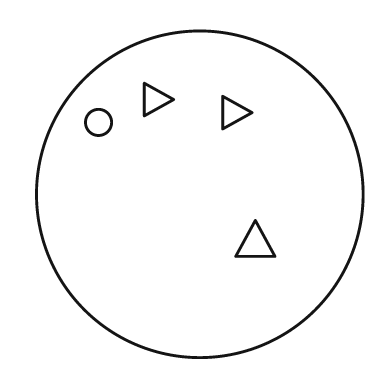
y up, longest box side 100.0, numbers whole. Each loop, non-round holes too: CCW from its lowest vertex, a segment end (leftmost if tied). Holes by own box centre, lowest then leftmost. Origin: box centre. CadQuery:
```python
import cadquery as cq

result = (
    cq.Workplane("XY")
    .moveTo(0.0, 0.0)
    .circle(50.0)
    .moveTo(11.0, -19.0)
    .lineTo(23.0, -19.0)
    .lineTo(17.0, -8.0)
    .close()
    .moveTo(-31.0, 22.0)
    .circle(4.0)
    .moveTo(7.0, 20.0)
    .lineTo(16.0, 25.0)
    .lineTo(7.0, 30.0)
    .close()
    .moveTo(-17.0, 24.0)
    .lineTo(-8.0, 29.0)
    .lineTo(-17.0, 34.0)
    .close()
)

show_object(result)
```